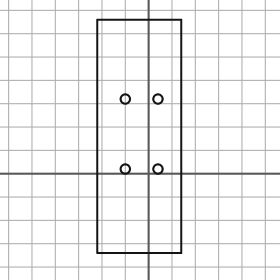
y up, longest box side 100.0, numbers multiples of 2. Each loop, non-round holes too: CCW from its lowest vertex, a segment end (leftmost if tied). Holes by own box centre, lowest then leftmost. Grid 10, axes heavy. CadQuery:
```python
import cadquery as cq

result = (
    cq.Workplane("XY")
    .moveTo(-22.0, -34.0)
    .lineTo(14.0, -34.0)
    .lineTo(14.0, 66.0)
    .lineTo(-22.0, 66.0)
    .close()
    .moveTo(-10.0, 2.0)
    .circle(2.0)
    .moveTo(4.0, 2.0)
    .circle(2.0)
    .moveTo(-10.0, 32.0)
    .circle(2.0)
    .moveTo(4.0, 32.0)
    .circle(2.0)
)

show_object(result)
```